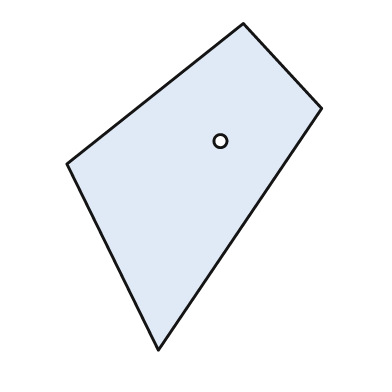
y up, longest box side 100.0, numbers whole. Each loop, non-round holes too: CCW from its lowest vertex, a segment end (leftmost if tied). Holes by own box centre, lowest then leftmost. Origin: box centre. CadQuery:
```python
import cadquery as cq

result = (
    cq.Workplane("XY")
    .moveTo(-11.0, -50.0)
    .lineTo(39.0, 24.0)
    .lineTo(15.0, 50.0)
    .lineTo(-39.0, 7.0)
    .close()
    .moveTo(8.0, 14.0)
    .circle(2.0)
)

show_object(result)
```